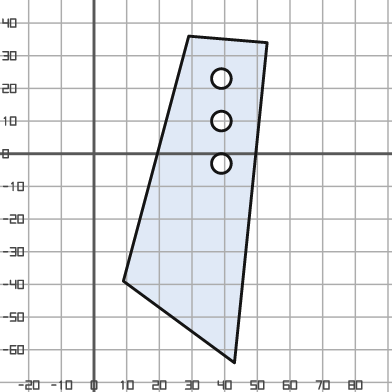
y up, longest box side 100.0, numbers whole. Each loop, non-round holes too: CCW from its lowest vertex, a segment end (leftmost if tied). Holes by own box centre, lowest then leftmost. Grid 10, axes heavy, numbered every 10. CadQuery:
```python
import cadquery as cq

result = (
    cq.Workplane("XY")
    .moveTo(43.0, -64.0)
    .lineTo(53.0, 34.0)
    .lineTo(29.0, 36.0)
    .lineTo(9.0, -39.0)
    .close()
    .moveTo(39.0, -3.0)
    .circle(3.0)
    .moveTo(39.0, 10.0)
    .circle(3.0)
    .moveTo(39.0, 23.0)
    .circle(3.0)
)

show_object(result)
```